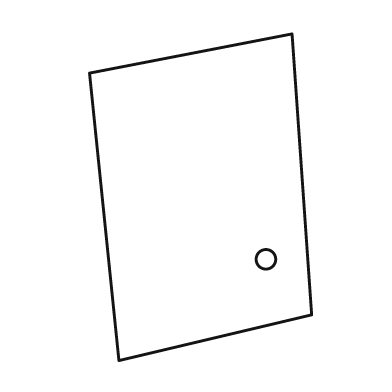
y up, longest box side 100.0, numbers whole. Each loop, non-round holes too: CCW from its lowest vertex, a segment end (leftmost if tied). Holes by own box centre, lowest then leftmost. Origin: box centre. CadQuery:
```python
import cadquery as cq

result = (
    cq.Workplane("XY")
    .moveTo(-25.0, -50.0)
    .lineTo(34.0, -36.0)
    .lineTo(28.0, 50.0)
    .lineTo(-34.0, 38.0)
    .close()
    .moveTo(20.0, -19.0)
    .circle(3.0)
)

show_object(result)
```